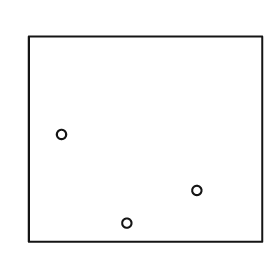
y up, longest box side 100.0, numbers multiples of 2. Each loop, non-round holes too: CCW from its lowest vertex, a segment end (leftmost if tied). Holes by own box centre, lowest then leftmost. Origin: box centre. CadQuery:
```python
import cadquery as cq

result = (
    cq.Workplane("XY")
    .moveTo(-50.0, -44.0)
    .lineTo(50.0, -44.0)
    .lineTo(50.0, 44.0)
    .lineTo(-50.0, 44.0)
    .close()
    .moveTo(-8.0, -36.0)
    .circle(2.0)
    .moveTo(22.0, -22.0)
    .circle(2.0)
    .moveTo(-36.0, 2.0)
    .circle(2.0)
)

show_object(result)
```